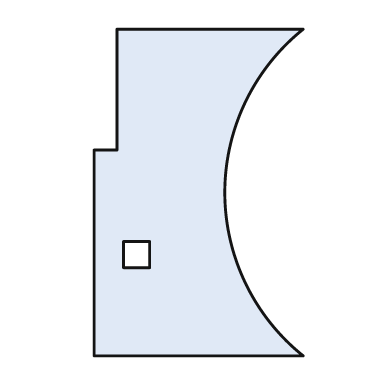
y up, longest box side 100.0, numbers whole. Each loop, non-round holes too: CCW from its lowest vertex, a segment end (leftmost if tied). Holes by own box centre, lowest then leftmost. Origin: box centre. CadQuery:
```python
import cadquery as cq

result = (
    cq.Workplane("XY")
    .moveTo(-32.0, -50.0)
    .lineTo(32.0, -50.0)
    .threePointArc((8.0, 0.0), (32.0, 50.0))
    .lineTo(-25.0, 50.0)
    .lineTo(-25.0, 13.0)
    .lineTo(-32.0, 13.0)
    .close()
    .moveTo(-23.0, -23.0)
    .lineTo(-15.0, -23.0)
    .lineTo(-15.0, -15.0)
    .lineTo(-23.0, -15.0)
    .close()
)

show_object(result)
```